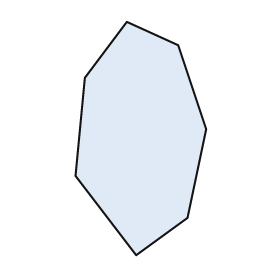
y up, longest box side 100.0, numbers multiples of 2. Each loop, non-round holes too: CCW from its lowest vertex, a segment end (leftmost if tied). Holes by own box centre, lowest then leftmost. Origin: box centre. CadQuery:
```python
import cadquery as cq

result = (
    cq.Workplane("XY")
    .moveTo(-2.0, -50.0)
    .lineTo(20.0, -34.0)
    .lineTo(28.0, 4.0)
    .lineTo(16.0, 40.0)
    .lineTo(-6.0, 50.0)
    .lineTo(-24.0, 26.0)
    .lineTo(-28.0, -16.0)
    .close()
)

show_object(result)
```